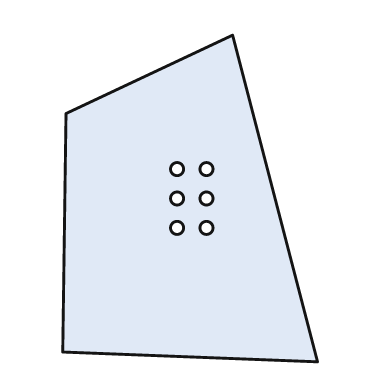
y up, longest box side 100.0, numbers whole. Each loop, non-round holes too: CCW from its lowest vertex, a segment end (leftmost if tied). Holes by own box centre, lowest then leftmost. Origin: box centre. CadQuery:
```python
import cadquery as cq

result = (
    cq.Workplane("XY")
    .moveTo(39.0, -50.0)
    .lineTo(13.0, 50.0)
    .lineTo(-38.0, 26.0)
    .lineTo(-39.0, -47.0)
    .close()
    .moveTo(-4.0, -9.0)
    .circle(2.0)
    .moveTo(5.0, -9.0)
    .circle(2.0)
    .moveTo(-4.0, 0.0)
    .circle(2.0)
    .moveTo(5.0, 0.0)
    .circle(2.0)
    .moveTo(-4.0, 9.0)
    .circle(2.0)
    .moveTo(5.0, 9.0)
    .circle(2.0)
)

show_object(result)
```